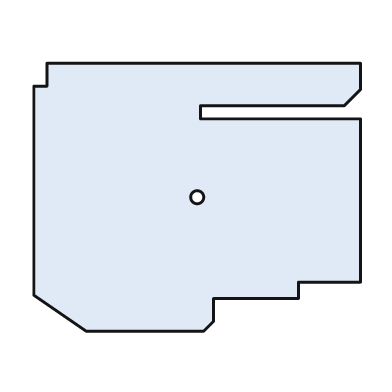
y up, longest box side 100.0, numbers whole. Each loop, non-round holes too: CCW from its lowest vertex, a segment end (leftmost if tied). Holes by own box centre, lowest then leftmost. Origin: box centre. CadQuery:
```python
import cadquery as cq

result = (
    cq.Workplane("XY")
    .moveTo(-34.0, -41.0)
    .lineTo(2.0, -41.0)
    .lineTo(5.0, -38.0)
    .lineTo(5.0, -31.0)
    .lineTo(31.0, -31.0)
    .lineTo(31.0, -26.0)
    .lineTo(50.0, -26.0)
    .lineTo(50.0, 24.0)
    .lineTo(1.0, 24.0)
    .lineTo(1.0, 28.0)
    .lineTo(45.0, 28.0)
    .lineTo(50.0, 33.0)
    .lineTo(50.0, 41.0)
    .lineTo(-46.0, 41.0)
    .lineTo(-46.0, 34.0)
    .lineTo(-50.0, 34.0)
    .lineTo(-50.0, -30.0)
    .close()
    .moveTo(0.0, 0.0)
    .circle(2.0)
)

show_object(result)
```